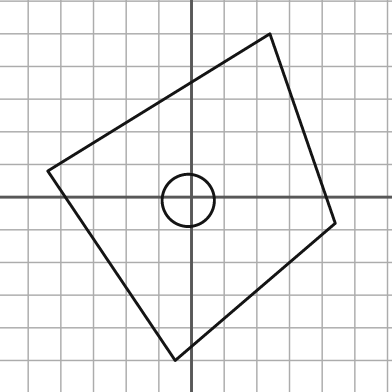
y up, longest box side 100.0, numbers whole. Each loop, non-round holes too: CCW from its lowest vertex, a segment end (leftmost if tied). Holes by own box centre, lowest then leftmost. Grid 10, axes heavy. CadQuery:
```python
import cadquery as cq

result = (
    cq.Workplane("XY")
    .moveTo(-5.0, -50.0)
    .lineTo(44.0, -8.0)
    .lineTo(24.0, 50.0)
    .lineTo(-44.0, 8.0)
    .close()
    .moveTo(-1.0, -1.0)
    .circle(8.0)
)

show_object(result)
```